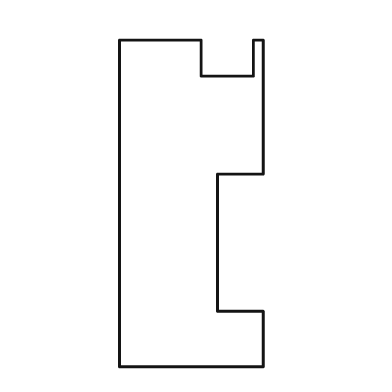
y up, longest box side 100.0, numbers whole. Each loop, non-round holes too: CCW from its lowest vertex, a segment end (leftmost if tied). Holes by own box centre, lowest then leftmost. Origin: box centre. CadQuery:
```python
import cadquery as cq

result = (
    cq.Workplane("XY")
    .moveTo(-22.0, -50.0)
    .lineTo(22.0, -50.0)
    .lineTo(22.0, -33.0)
    .lineTo(8.0, -33.0)
    .lineTo(8.0, 9.0)
    .lineTo(22.0, 9.0)
    .lineTo(22.0, 50.0)
    .lineTo(19.0, 50.0)
    .lineTo(19.0, 39.0)
    .lineTo(3.0, 39.0)
    .lineTo(3.0, 50.0)
    .lineTo(-22.0, 50.0)
    .close()
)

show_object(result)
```